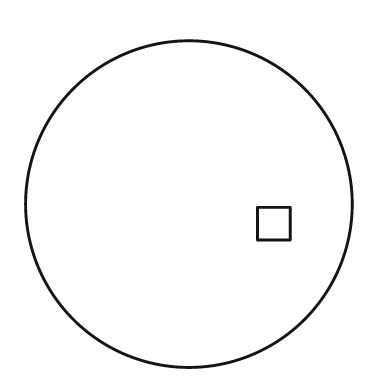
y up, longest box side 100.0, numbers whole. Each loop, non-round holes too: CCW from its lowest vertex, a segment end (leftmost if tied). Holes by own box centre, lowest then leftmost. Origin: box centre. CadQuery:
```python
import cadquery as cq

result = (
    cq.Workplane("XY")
    .moveTo(0.0, 0.0)
    .circle(50.0)
    .moveTo(21.0, -11.0)
    .lineTo(31.0, -11.0)
    .lineTo(31.0, -1.0)
    .lineTo(21.0, -1.0)
    .close()
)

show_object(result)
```